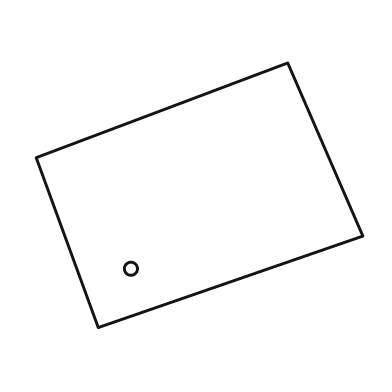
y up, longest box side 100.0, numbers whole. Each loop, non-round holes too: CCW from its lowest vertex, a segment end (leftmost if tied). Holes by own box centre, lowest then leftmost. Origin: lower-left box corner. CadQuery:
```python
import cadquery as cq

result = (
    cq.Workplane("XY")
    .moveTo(19.0, 0.0)
    .lineTo(100.0, 28.0)
    .lineTo(77.0, 81.0)
    .lineTo(0.0, 52.0)
    .close()
    .moveTo(29.0, 18.0)
    .circle(2.0)
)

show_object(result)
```